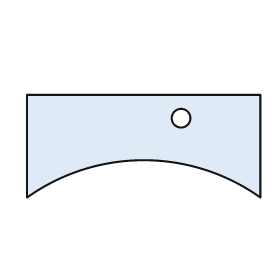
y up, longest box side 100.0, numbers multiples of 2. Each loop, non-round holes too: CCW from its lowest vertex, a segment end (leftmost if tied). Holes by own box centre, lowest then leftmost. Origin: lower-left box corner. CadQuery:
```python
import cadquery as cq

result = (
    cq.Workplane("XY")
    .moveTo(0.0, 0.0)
    .threePointArc((50.0, 16.0), (100.0, 0.0))
    .lineTo(100.0, 44.0)
    .lineTo(0.0, 44.0)
    .close()
    .moveTo(66.0, 34.0)
    .circle(4.0)
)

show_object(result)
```